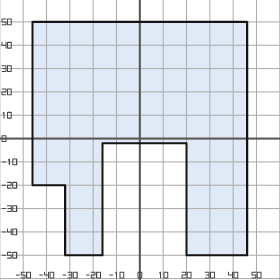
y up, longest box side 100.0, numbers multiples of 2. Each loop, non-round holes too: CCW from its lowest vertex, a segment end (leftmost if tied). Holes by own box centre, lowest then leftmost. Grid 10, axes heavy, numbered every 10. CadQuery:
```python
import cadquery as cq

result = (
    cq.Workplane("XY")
    .moveTo(-32.0, -50.0)
    .lineTo(-16.0, -50.0)
    .lineTo(-16.0, -2.0)
    .lineTo(20.0, -2.0)
    .lineTo(20.0, -50.0)
    .lineTo(46.0, -50.0)
    .lineTo(46.0, 50.0)
    .lineTo(-46.0, 50.0)
    .lineTo(-46.0, -20.0)
    .lineTo(-32.0, -20.0)
    .close()
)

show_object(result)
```